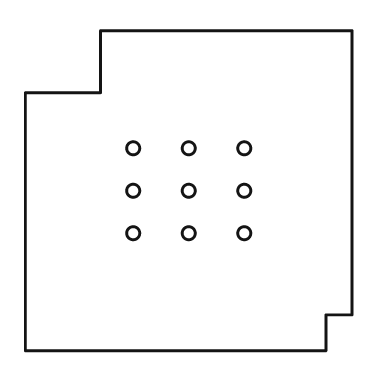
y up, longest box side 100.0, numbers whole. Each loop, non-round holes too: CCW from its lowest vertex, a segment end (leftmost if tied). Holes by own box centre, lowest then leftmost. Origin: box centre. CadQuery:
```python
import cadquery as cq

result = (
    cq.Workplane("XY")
    .moveTo(-50.0, -49.0)
    .lineTo(42.0, -49.0)
    .lineTo(42.0, -38.0)
    .lineTo(50.0, -38.0)
    .lineTo(50.0, 49.0)
    .lineTo(-27.0, 49.0)
    .lineTo(-27.0, 30.0)
    .lineTo(-50.0, 30.0)
    .close()
    .moveTo(-17.0, -13.0)
    .circle(2.0)
    .moveTo(0.0, -13.0)
    .circle(2.0)
    .moveTo(17.0, -13.0)
    .circle(2.0)
    .moveTo(-17.0, 0.0)
    .circle(2.0)
    .moveTo(0.0, 0.0)
    .circle(2.0)
    .moveTo(17.0, 0.0)
    .circle(2.0)
    .moveTo(-17.0, 13.0)
    .circle(2.0)
    .moveTo(0.0, 13.0)
    .circle(2.0)
    .moveTo(17.0, 13.0)
    .circle(2.0)
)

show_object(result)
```